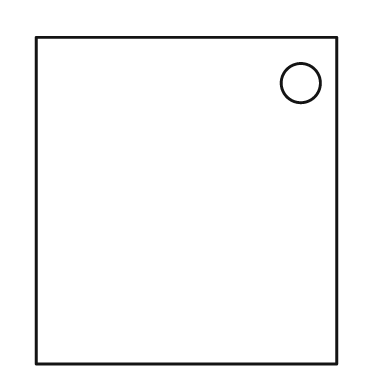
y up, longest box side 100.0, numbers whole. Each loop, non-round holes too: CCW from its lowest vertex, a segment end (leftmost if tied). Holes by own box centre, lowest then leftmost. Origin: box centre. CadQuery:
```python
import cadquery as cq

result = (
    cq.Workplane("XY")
    .moveTo(-46.0, -50.0)
    .lineTo(46.0, -50.0)
    .lineTo(46.0, 50.0)
    .lineTo(-46.0, 50.0)
    .close()
    .moveTo(35.0, 36.0)
    .circle(6.0)
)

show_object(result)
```